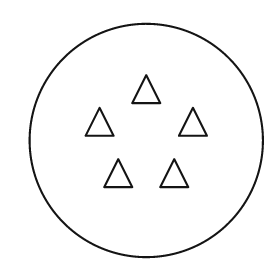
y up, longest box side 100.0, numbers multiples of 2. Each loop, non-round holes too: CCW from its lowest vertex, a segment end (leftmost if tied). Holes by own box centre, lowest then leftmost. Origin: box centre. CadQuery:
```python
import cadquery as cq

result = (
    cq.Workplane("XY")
    .moveTo(0.0, 0.0)
    .circle(50.0)
    .moveTo(-18.0, -20.0)
    .lineTo(-6.0, -20.0)
    .lineTo(-12.0, -8.0)
    .close()
    .moveTo(6.0, -20.0)
    .lineTo(18.0, -20.0)
    .lineTo(12.0, -8.0)
    .close()
    .moveTo(-26.0, 2.0)
    .lineTo(-14.0, 2.0)
    .lineTo(-20.0, 14.0)
    .close()
    .moveTo(14.0, 2.0)
    .lineTo(26.0, 2.0)
    .lineTo(20.0, 14.0)
    .close()
    .moveTo(-6.0, 16.0)
    .lineTo(6.0, 16.0)
    .lineTo(0.0, 28.0)
    .close()
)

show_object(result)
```